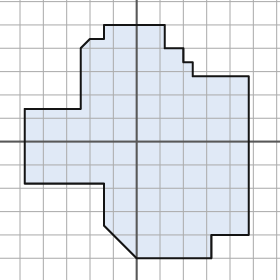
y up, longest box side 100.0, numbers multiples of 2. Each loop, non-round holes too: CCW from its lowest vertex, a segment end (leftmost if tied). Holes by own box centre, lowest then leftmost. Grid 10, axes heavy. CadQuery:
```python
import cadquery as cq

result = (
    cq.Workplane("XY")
    .moveTo(0.0, -50.0)
    .lineTo(32.0, -50.0)
    .lineTo(32.0, -40.0)
    .lineTo(48.0, -40.0)
    .lineTo(48.0, 28.0)
    .lineTo(24.0, 28.0)
    .lineTo(24.0, 34.0)
    .lineTo(20.0, 34.0)
    .lineTo(20.0, 40.0)
    .lineTo(12.0, 40.0)
    .lineTo(12.0, 50.0)
    .lineTo(-14.0, 50.0)
    .lineTo(-14.0, 44.0)
    .lineTo(-20.0, 44.0)
    .lineTo(-24.0, 40.0)
    .lineTo(-24.0, 14.0)
    .lineTo(-48.0, 14.0)
    .lineTo(-48.0, -18.0)
    .lineTo(-14.0, -18.0)
    .lineTo(-14.0, -36.0)
    .close()
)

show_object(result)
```